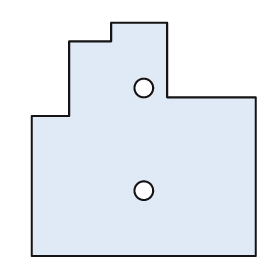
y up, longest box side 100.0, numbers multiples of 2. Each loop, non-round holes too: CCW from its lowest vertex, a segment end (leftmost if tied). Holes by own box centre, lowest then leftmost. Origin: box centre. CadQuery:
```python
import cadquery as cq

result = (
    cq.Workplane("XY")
    .moveTo(-48.0, -50.0)
    .lineTo(48.0, -50.0)
    .lineTo(48.0, 18.0)
    .lineTo(10.0, 18.0)
    .lineTo(10.0, 50.0)
    .lineTo(-14.0, 50.0)
    .lineTo(-14.0, 42.0)
    .lineTo(-32.0, 42.0)
    .lineTo(-32.0, 10.0)
    .lineTo(-48.0, 10.0)
    .close()
    .moveTo(0.0, -22.0)
    .circle(4.0)
    .moveTo(0.0, 22.0)
    .circle(4.0)
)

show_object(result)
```